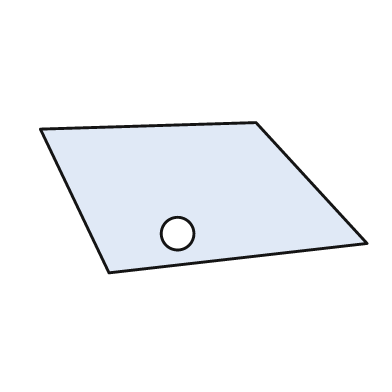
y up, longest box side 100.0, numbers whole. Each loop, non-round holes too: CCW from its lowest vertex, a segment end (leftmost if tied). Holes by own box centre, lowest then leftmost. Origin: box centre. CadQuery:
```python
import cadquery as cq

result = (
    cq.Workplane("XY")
    .moveTo(-29.0, -23.0)
    .lineTo(50.0, -14.0)
    .lineTo(16.0, 23.0)
    .lineTo(-50.0, 21.0)
    .close()
    .moveTo(-8.0, -11.0)
    .circle(5.0)
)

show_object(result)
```